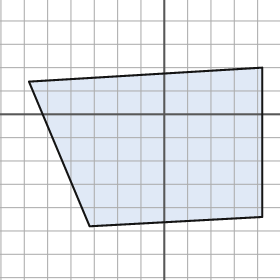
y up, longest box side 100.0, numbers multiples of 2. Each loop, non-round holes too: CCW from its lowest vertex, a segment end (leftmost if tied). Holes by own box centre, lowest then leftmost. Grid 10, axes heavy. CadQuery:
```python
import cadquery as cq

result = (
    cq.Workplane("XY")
    .moveTo(-32.0, -48.0)
    .lineTo(42.0, -44.0)
    .lineTo(42.0, 20.0)
    .lineTo(-58.0, 14.0)
    .close()
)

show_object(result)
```